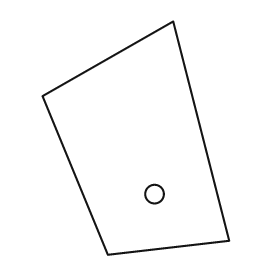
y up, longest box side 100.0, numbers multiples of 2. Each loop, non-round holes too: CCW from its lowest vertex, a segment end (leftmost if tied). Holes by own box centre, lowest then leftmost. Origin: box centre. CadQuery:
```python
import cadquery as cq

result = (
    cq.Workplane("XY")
    .moveTo(-12.0, -50.0)
    .lineTo(40.0, -44.0)
    .lineTo(16.0, 50.0)
    .lineTo(-40.0, 18.0)
    .close()
    .moveTo(8.0, -24.0)
    .circle(4.0)
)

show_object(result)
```